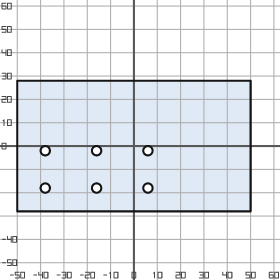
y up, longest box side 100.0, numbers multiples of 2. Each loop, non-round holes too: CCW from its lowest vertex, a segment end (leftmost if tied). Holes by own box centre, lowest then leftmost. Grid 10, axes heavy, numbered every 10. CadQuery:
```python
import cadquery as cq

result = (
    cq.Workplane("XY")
    .moveTo(-50.0, -28.0)
    .lineTo(50.0, -28.0)
    .lineTo(50.0, 28.0)
    .lineTo(-50.0, 28.0)
    .close()
    .moveTo(-38.0, -18.0)
    .circle(2.0)
    .moveTo(-16.0, -18.0)
    .circle(2.0)
    .moveTo(6.0, -18.0)
    .circle(2.0)
    .moveTo(-38.0, -2.0)
    .circle(2.0)
    .moveTo(-16.0, -2.0)
    .circle(2.0)
    .moveTo(6.0, -2.0)
    .circle(2.0)
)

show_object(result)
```